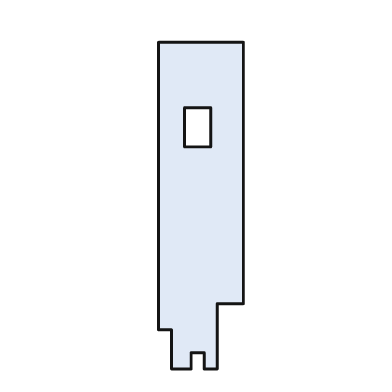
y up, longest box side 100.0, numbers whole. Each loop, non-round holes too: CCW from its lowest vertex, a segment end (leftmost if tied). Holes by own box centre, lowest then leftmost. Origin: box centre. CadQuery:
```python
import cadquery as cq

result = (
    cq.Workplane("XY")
    .moveTo(-9.0, -50.0)
    .lineTo(-3.0, -50.0)
    .lineTo(-3.0, -45.0)
    .lineTo(1.0, -45.0)
    .lineTo(1.0, -50.0)
    .lineTo(5.0, -50.0)
    .lineTo(5.0, -30.0)
    .lineTo(13.0, -30.0)
    .lineTo(13.0, 50.0)
    .lineTo(-13.0, 50.0)
    .lineTo(-13.0, -38.0)
    .lineTo(-9.0, -38.0)
    .close()
    .moveTo(-5.0, 18.0)
    .lineTo(3.0, 18.0)
    .lineTo(3.0, 30.0)
    .lineTo(-5.0, 30.0)
    .close()
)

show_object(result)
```